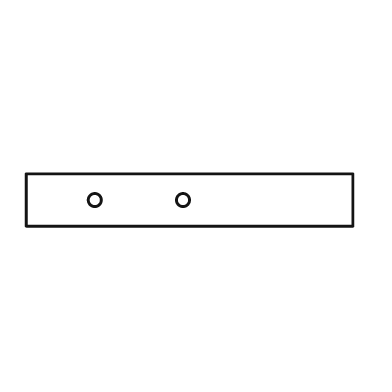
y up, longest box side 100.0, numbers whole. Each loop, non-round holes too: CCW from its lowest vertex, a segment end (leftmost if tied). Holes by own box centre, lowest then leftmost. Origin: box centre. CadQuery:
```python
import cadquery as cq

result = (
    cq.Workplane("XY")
    .moveTo(-50.0, -8.0)
    .lineTo(50.0, -8.0)
    .lineTo(50.0, 8.0)
    .lineTo(-50.0, 8.0)
    .close()
    .moveTo(-29.0, 0.0)
    .circle(2.0)
    .moveTo(-2.0, 0.0)
    .circle(2.0)
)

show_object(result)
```